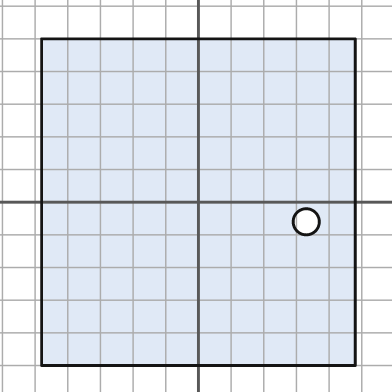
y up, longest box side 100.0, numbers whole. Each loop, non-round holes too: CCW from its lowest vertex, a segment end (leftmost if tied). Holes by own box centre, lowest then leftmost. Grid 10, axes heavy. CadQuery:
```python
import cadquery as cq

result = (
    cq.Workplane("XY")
    .moveTo(-48.0, -50.0)
    .lineTo(48.0, -50.0)
    .lineTo(48.0, 50.0)
    .lineTo(-48.0, 50.0)
    .close()
    .moveTo(33.0, -6.0)
    .circle(4.0)
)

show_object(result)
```